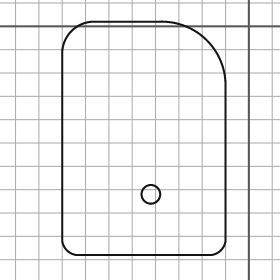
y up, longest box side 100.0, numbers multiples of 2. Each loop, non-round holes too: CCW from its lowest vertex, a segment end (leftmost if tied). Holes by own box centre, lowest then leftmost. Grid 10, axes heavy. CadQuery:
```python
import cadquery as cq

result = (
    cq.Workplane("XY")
    .moveTo(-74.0, -98.0)
    .lineTo(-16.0, -98.0)
    .threePointArc((-12.0, -96.0), (-10.0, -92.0))
    .lineTo(-10.0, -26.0)
    .threePointArc((-18.0, -6.0), (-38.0, 2.0))
    .lineTo(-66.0, 2.0)
    .threePointArc((-76.0, -2.0), (-80.0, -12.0))
    .lineTo(-80.0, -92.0)
    .threePointArc((-78.0, -96.0), (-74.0, -98.0))
    .close()
    .moveTo(-42.0, -72.0)
    .circle(4.0)
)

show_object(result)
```